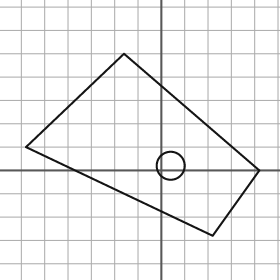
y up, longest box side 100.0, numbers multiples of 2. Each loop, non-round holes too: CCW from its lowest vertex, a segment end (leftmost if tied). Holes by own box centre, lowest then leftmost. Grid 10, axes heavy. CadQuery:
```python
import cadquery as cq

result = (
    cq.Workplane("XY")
    .moveTo(22.0, -28.0)
    .lineTo(42.0, 0.0)
    .lineTo(-16.0, 50.0)
    .lineTo(-58.0, 10.0)
    .close()
    .moveTo(4.0, 2.0)
    .circle(6.0)
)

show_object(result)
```